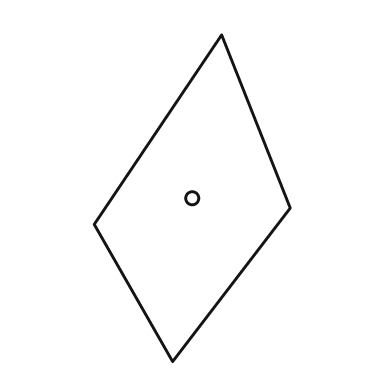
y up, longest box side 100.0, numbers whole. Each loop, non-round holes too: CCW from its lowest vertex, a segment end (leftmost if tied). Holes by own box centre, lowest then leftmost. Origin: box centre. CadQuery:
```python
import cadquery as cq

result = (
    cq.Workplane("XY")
    .moveTo(-6.0, -50.0)
    .lineTo(30.0, -3.0)
    .lineTo(9.0, 50.0)
    .lineTo(-30.0, -8.0)
    .close()
    .moveTo(0.0, 0.0)
    .circle(2.0)
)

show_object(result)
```